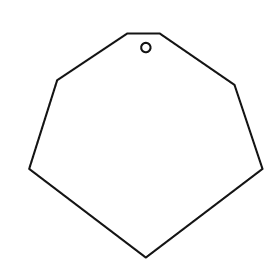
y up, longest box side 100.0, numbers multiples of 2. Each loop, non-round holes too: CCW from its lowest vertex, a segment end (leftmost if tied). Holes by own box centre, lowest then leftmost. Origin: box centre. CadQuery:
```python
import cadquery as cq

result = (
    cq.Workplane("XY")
    .moveTo(0.0, -48.0)
    .lineTo(50.0, -10.0)
    .lineTo(38.0, 26.0)
    .lineTo(6.0, 48.0)
    .lineTo(-8.0, 48.0)
    .lineTo(-38.0, 28.0)
    .lineTo(-50.0, -10.0)
    .close()
    .moveTo(0.0, 42.0)
    .circle(2.0)
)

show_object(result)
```